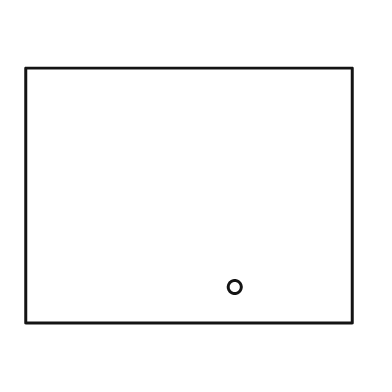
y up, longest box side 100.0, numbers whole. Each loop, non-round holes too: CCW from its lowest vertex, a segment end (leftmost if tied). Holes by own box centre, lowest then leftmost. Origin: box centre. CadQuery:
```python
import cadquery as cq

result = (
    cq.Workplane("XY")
    .moveTo(-50.0, -39.0)
    .lineTo(50.0, -39.0)
    .lineTo(50.0, 39.0)
    .lineTo(-50.0, 39.0)
    .close()
    .moveTo(14.0, -28.0)
    .circle(2.0)
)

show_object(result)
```